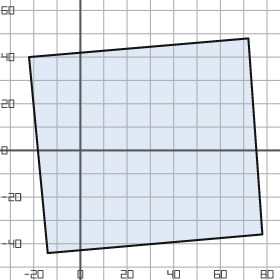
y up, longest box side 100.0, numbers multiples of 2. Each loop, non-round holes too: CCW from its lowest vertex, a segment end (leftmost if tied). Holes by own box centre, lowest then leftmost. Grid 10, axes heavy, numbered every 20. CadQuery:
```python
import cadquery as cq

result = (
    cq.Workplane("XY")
    .moveTo(-14.0, -44.0)
    .lineTo(78.0, -36.0)
    .lineTo(72.0, 48.0)
    .lineTo(-22.0, 40.0)
    .close()
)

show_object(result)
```